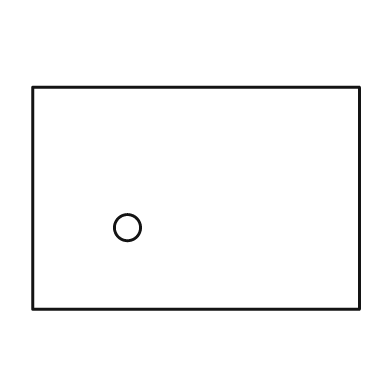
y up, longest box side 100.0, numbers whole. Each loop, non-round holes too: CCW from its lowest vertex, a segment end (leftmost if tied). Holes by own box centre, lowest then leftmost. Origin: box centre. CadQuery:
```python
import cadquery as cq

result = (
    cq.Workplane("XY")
    .moveTo(-50.0, -34.0)
    .lineTo(50.0, -34.0)
    .lineTo(50.0, 34.0)
    .lineTo(-50.0, 34.0)
    .close()
    .moveTo(-21.0, -9.0)
    .circle(4.0)
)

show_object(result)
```